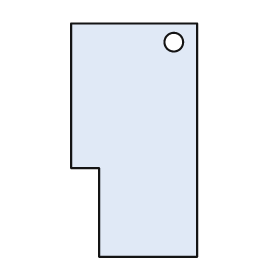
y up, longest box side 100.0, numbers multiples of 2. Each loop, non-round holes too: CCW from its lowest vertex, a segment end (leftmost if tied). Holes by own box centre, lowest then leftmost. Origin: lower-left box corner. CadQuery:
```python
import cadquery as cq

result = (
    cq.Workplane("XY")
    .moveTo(12.0, 0.0)
    .lineTo(54.0, 0.0)
    .lineTo(54.0, 100.0)
    .lineTo(0.0, 100.0)
    .lineTo(0.0, 38.0)
    .lineTo(12.0, 38.0)
    .close()
    .moveTo(44.0, 92.0)
    .circle(4.0)
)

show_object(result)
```